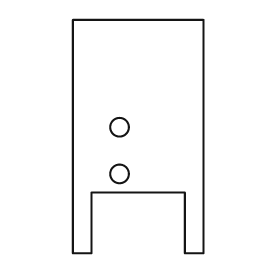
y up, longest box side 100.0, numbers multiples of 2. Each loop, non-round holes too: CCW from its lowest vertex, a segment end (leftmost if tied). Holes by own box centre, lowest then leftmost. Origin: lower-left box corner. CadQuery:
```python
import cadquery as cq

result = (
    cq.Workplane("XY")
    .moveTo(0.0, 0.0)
    .lineTo(8.0, 0.0)
    .lineTo(8.0, 26.0)
    .lineTo(48.0, 26.0)
    .lineTo(48.0, 0.0)
    .lineTo(56.0, 0.0)
    .lineTo(56.0, 100.0)
    .lineTo(0.0, 100.0)
    .close()
    .moveTo(20.0, 34.0)
    .circle(4.0)
    .moveTo(20.0, 54.0)
    .circle(4.0)
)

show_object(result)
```